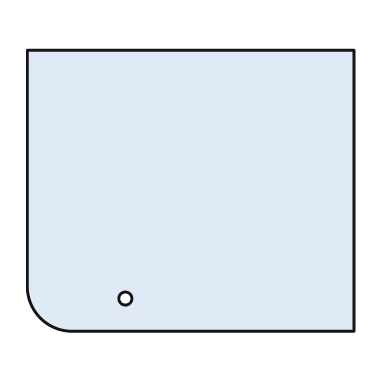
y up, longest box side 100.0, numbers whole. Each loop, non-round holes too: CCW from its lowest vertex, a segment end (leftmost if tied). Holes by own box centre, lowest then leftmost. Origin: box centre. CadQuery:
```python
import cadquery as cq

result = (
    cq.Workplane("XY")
    .moveTo(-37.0, -43.0)
    .lineTo(50.0, -43.0)
    .lineTo(50.0, 43.0)
    .lineTo(-50.0, 43.0)
    .lineTo(-50.0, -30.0)
    .threePointArc((-46.0, -39.0), (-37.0, -43.0))
    .close()
    .moveTo(-20.0, -33.0)
    .circle(2.0)
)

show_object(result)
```